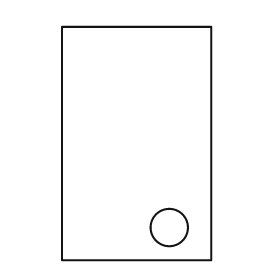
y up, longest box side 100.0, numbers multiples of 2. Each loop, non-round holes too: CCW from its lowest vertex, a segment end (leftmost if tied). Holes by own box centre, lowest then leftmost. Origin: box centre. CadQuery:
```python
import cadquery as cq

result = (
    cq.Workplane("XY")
    .moveTo(-32.0, -50.0)
    .lineTo(32.0, -50.0)
    .lineTo(32.0, 50.0)
    .lineTo(-32.0, 50.0)
    .close()
    .moveTo(14.0, -36.0)
    .circle(8.0)
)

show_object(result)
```